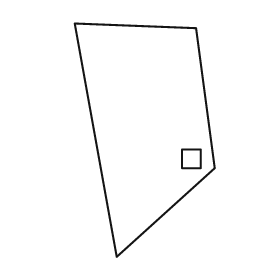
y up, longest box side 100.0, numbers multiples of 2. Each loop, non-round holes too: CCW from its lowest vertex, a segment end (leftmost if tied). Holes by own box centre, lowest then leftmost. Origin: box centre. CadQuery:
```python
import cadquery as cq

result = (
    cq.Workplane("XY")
    .moveTo(-12.0, -50.0)
    .lineTo(30.0, -12.0)
    .lineTo(22.0, 48.0)
    .lineTo(-30.0, 50.0)
    .close()
    .moveTo(16.0, -12.0)
    .lineTo(24.0, -12.0)
    .lineTo(24.0, -4.0)
    .lineTo(16.0, -4.0)
    .close()
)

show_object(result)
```